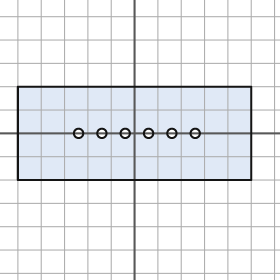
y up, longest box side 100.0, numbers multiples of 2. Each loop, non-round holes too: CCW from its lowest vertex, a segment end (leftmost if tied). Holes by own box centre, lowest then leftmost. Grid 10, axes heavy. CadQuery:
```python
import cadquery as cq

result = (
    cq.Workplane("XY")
    .moveTo(-50.0, -20.0)
    .lineTo(50.0, -20.0)
    .lineTo(50.0, 20.0)
    .lineTo(-50.0, 20.0)
    .close()
    .moveTo(-24.0, 0.0)
    .circle(2.0)
    .moveTo(-14.0, 0.0)
    .circle(2.0)
    .moveTo(-4.0, 0.0)
    .circle(2.0)
    .moveTo(6.0, 0.0)
    .circle(2.0)
    .moveTo(16.0, 0.0)
    .circle(2.0)
    .moveTo(26.0, 0.0)
    .circle(2.0)
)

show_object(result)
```